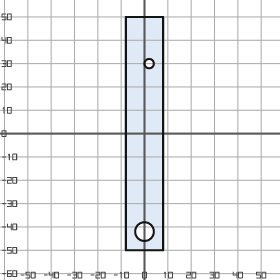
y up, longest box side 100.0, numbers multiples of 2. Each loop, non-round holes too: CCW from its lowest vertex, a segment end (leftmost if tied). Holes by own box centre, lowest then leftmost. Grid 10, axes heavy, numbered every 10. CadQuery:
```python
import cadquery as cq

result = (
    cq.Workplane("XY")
    .moveTo(-8.0, -50.0)
    .lineTo(8.0, -50.0)
    .lineTo(8.0, 50.0)
    .lineTo(-8.0, 50.0)
    .close()
    .moveTo(0.0, -42.0)
    .circle(4.0)
    .moveTo(2.0, 30.0)
    .circle(2.0)
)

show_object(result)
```